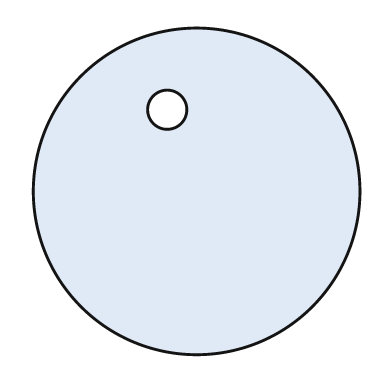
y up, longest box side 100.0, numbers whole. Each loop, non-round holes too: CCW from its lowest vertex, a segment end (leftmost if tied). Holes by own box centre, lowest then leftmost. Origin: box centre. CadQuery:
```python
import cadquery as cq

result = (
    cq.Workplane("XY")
    .moveTo(0.0, 0.0)
    .circle(50.0)
    .moveTo(-9.0, 25.0)
    .circle(6.0)
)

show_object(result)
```